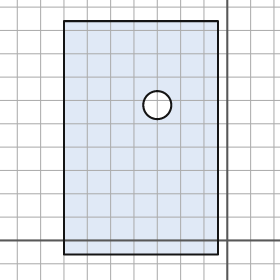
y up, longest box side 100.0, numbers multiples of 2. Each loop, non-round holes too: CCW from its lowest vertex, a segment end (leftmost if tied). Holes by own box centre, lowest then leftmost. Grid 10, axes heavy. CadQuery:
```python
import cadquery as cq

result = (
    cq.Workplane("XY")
    .moveTo(-70.0, -6.0)
    .lineTo(-4.0, -6.0)
    .lineTo(-4.0, 94.0)
    .lineTo(-70.0, 94.0)
    .close()
    .moveTo(-30.0, 58.0)
    .circle(6.0)
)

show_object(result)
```